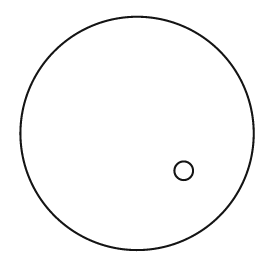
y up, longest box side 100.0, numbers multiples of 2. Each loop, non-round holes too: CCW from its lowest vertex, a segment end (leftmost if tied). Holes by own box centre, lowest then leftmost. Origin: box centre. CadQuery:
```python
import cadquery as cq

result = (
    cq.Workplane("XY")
    .moveTo(0.0, 0.0)
    .circle(50.0)
    .moveTo(20.0, -16.0)
    .circle(4.0)
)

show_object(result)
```